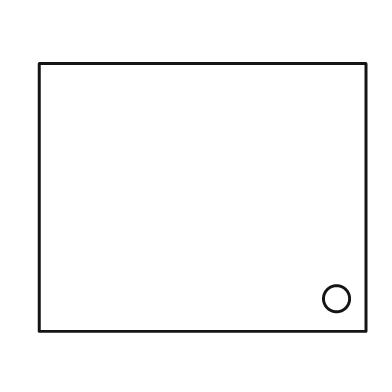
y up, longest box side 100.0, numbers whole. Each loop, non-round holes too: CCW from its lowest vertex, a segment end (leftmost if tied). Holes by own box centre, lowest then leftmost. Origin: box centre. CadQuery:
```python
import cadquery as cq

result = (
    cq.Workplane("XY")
    .moveTo(-50.0, -41.0)
    .lineTo(50.0, -41.0)
    .lineTo(50.0, 41.0)
    .lineTo(-50.0, 41.0)
    .close()
    .moveTo(41.0, -31.0)
    .circle(4.0)
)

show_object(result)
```